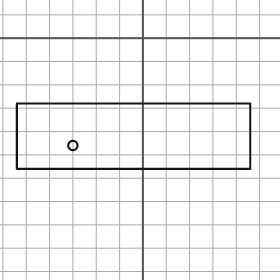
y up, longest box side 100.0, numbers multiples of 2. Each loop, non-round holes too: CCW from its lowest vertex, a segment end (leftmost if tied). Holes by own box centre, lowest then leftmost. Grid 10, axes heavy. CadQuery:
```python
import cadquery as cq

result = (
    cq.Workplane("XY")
    .moveTo(-54.0, -56.0)
    .lineTo(46.0, -56.0)
    .lineTo(46.0, -28.0)
    .lineTo(-54.0, -28.0)
    .close()
    .moveTo(-30.0, -46.0)
    .circle(2.0)
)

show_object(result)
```